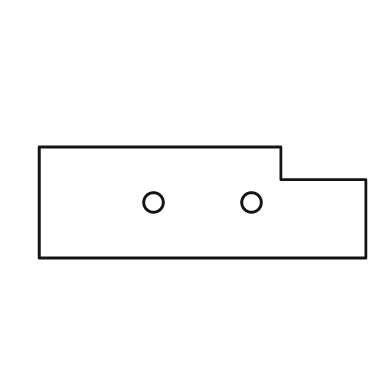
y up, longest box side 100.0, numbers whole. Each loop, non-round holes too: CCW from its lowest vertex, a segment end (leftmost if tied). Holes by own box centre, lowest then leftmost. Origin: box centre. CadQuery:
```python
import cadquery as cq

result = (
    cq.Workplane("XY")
    .moveTo(-50.0, -17.0)
    .lineTo(50.0, -17.0)
    .lineTo(50.0, 7.0)
    .lineTo(24.0, 7.0)
    .lineTo(24.0, 17.0)
    .lineTo(-50.0, 17.0)
    .close()
    .moveTo(-15.0, 0.0)
    .circle(3.0)
    .moveTo(15.0, 0.0)
    .circle(3.0)
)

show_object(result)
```